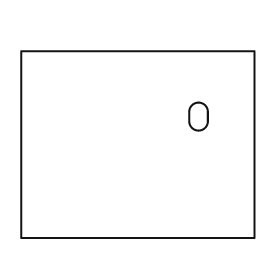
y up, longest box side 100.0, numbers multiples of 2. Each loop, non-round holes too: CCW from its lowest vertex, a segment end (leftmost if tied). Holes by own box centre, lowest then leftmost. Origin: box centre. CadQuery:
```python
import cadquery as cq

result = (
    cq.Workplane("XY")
    .moveTo(-50.0, -40.0)
    .lineTo(50.0, -40.0)
    .lineTo(50.0, 40.0)
    .lineTo(-50.0, 40.0)
    .close()
    .moveTo(22.0, 10.0)
    .threePointArc((26.0, 6.0), (30.0, 10.0))
    .lineTo(30.0, 14.0)
    .threePointArc((26.0, 18.0), (22.0, 14.0))
    .close()
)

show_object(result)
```